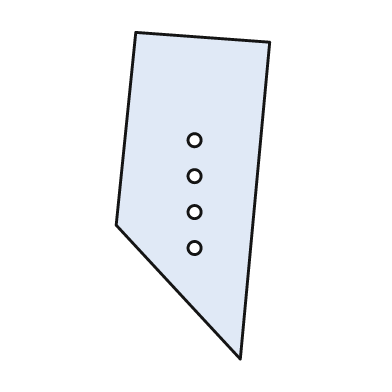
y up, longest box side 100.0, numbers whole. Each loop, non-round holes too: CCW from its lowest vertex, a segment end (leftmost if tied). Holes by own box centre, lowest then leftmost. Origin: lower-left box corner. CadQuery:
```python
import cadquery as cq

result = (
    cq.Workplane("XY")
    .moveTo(38.0, 0.0)
    .lineTo(47.0, 97.0)
    .lineTo(6.0, 100.0)
    .lineTo(0.0, 41.0)
    .close()
    .moveTo(24.0, 34.0)
    .circle(2.0)
    .moveTo(24.0, 45.0)
    .circle(2.0)
    .moveTo(24.0, 56.0)
    .circle(2.0)
    .moveTo(24.0, 67.0)
    .circle(2.0)
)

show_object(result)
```